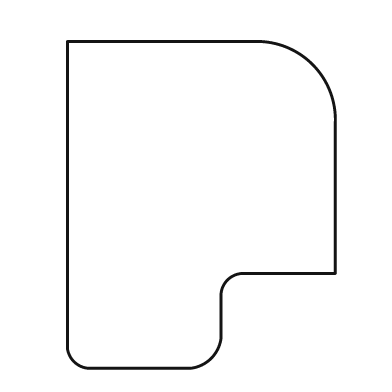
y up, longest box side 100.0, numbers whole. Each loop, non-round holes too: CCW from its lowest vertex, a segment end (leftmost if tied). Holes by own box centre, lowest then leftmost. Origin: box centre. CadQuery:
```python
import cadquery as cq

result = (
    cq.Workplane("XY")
    .moveTo(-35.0, -50.0)
    .lineTo(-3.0, -50.0)
    .threePointArc((3.0, -47.0), (6.0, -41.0))
    .lineTo(6.0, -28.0)
    .threePointArc((8.0, -23.0), (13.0, -21.0))
    .lineTo(41.0, -21.0)
    .lineTo(41.0, 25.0)
    .threePointArc((34.0, 43.0), (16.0, 50.0))
    .lineTo(-41.0, 50.0)
    .lineTo(-41.0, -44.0)
    .threePointArc((-39.0, -48.0), (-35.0, -50.0))
    .close()
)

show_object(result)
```